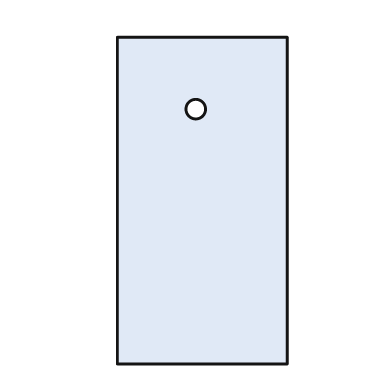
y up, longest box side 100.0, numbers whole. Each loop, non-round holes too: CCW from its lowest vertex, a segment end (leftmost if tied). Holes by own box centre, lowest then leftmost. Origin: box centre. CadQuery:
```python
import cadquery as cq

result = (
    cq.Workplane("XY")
    .moveTo(-26.0, -50.0)
    .lineTo(26.0, -50.0)
    .lineTo(26.0, 50.0)
    .lineTo(-26.0, 50.0)
    .close()
    .moveTo(-2.0, 28.0)
    .circle(3.0)
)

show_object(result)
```